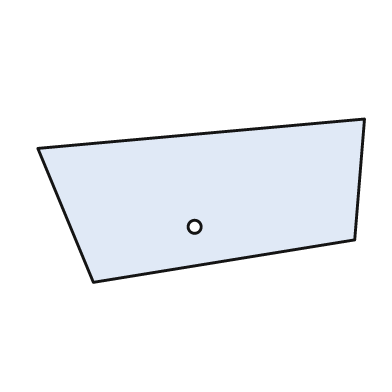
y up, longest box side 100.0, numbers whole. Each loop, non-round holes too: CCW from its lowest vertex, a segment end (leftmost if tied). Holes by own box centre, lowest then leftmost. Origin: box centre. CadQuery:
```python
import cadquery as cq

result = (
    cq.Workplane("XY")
    .moveTo(-33.0, -25.0)
    .lineTo(47.0, -12.0)
    .lineTo(50.0, 25.0)
    .lineTo(-50.0, 16.0)
    .close()
    .moveTo(-2.0, -8.0)
    .circle(2.0)
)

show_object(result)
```